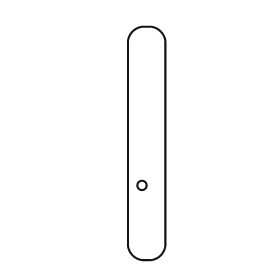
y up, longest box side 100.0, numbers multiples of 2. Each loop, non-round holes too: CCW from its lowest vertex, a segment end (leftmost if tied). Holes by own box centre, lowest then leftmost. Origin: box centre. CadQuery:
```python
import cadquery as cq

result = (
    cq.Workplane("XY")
    .moveTo(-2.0, -50.0)
    .lineTo(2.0, -50.0)
    .threePointArc((6.0, -48.0), (8.0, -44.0))
    .lineTo(8.0, 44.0)
    .threePointArc((6.0, 48.0), (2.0, 50.0))
    .lineTo(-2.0, 50.0)
    .threePointArc((-6.0, 48.0), (-8.0, 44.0))
    .lineTo(-8.0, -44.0)
    .threePointArc((-6.0, -48.0), (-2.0, -50.0))
    .close()
    .moveTo(-2.0, -18.0)
    .circle(2.0)
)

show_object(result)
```